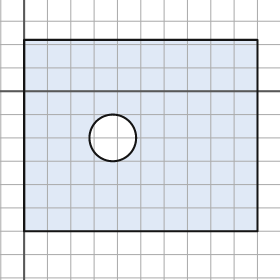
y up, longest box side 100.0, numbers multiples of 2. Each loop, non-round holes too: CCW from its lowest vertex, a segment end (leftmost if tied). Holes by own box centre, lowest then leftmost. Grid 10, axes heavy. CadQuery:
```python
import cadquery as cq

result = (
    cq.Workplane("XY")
    .moveTo(0.0, -60.0)
    .lineTo(100.0, -60.0)
    .lineTo(100.0, 22.0)
    .lineTo(0.0, 22.0)
    .close()
    .moveTo(38.0, -20.0)
    .circle(10.0)
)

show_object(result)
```